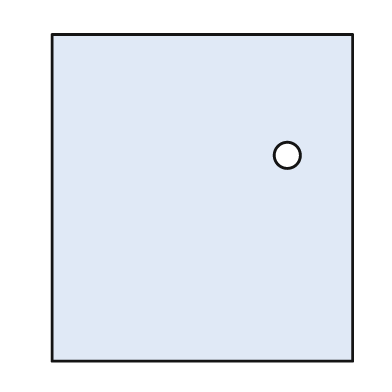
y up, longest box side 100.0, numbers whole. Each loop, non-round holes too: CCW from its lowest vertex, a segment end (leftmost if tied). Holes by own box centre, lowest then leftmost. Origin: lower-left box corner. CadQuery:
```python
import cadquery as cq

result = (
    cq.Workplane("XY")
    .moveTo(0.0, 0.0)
    .lineTo(92.0, 0.0)
    .lineTo(92.0, 100.0)
    .lineTo(0.0, 100.0)
    .close()
    .moveTo(72.0, 63.0)
    .circle(4.0)
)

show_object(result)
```